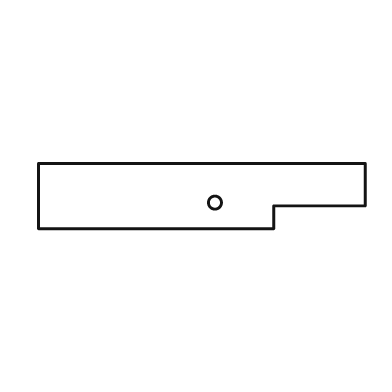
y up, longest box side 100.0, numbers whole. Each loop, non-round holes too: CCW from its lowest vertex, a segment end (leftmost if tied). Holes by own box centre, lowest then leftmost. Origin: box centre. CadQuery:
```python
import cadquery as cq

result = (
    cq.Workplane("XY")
    .moveTo(-50.0, -10.0)
    .lineTo(22.0, -10.0)
    .lineTo(22.0, -3.0)
    .lineTo(50.0, -3.0)
    .lineTo(50.0, 10.0)
    .lineTo(-50.0, 10.0)
    .close()
    .moveTo(4.0, -2.0)
    .circle(2.0)
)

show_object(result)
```